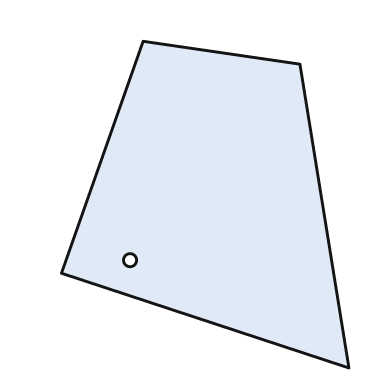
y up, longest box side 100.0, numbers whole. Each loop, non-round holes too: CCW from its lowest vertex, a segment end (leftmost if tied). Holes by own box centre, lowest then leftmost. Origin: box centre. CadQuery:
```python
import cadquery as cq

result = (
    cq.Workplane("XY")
    .moveTo(44.0, -50.0)
    .lineTo(29.0, 43.0)
    .lineTo(-19.0, 50.0)
    .lineTo(-44.0, -21.0)
    .close()
    .moveTo(-23.0, -17.0)
    .circle(2.0)
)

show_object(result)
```